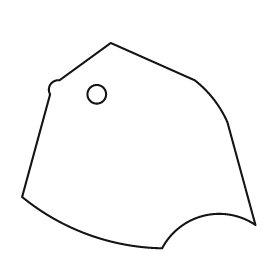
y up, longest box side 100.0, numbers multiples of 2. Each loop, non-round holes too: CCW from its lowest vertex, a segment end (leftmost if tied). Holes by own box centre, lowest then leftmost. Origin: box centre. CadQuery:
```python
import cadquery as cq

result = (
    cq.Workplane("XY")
    .moveTo(10.0, -44.0)
    .threePointArc((28.0, -30.0), (50.0, -34.0))
    .lineTo(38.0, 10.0)
    .threePointArc((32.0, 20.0), (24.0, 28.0))
    .lineTo(-12.0, 44.0)
    .lineTo(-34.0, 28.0)
    .threePointArc((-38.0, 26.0), (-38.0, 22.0))
    .lineTo(-50.0, -22.0)
    .threePointArc((-22.0, -38.0), (10.0, -44.0))
    .close()
    .moveTo(-18.0, 22.0)
    .circle(4.0)
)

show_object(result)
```